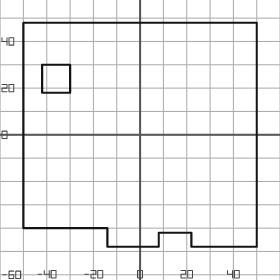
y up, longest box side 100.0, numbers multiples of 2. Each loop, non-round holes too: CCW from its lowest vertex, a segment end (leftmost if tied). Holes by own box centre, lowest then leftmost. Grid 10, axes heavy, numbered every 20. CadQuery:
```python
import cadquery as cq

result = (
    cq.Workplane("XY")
    .moveTo(-14.0, -48.0)
    .lineTo(8.0, -48.0)
    .lineTo(8.0, -42.0)
    .lineTo(22.0, -42.0)
    .lineTo(22.0, -48.0)
    .lineTo(50.0, -48.0)
    .lineTo(50.0, 48.0)
    .lineTo(-50.0, 48.0)
    .lineTo(-50.0, -40.0)
    .lineTo(-14.0, -40.0)
    .close()
    .moveTo(-42.0, 18.0)
    .lineTo(-30.0, 18.0)
    .lineTo(-30.0, 30.0)
    .lineTo(-42.0, 30.0)
    .close()
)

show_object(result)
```